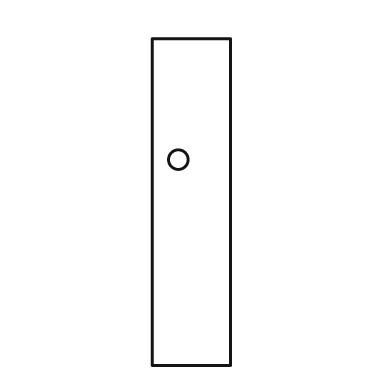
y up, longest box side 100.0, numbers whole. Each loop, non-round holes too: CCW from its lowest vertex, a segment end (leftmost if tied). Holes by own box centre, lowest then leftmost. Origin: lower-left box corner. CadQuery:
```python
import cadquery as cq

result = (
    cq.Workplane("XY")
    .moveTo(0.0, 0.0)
    .lineTo(24.0, 0.0)
    .lineTo(24.0, 100.0)
    .lineTo(0.0, 100.0)
    .close()
    .moveTo(8.0, 63.0)
    .circle(3.0)
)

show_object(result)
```